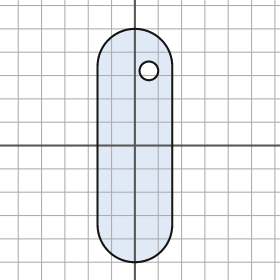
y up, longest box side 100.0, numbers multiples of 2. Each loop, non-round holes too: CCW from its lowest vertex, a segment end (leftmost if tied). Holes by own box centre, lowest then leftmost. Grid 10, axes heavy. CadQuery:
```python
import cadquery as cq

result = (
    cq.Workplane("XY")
    .moveTo(-16.0, -34.0)
    .threePointArc((0.0, -50.0), (16.0, -34.0))
    .lineTo(16.0, 34.0)
    .threePointArc((0.0, 50.0), (-16.0, 34.0))
    .close()
    .moveTo(6.0, 32.0)
    .circle(4.0)
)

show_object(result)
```